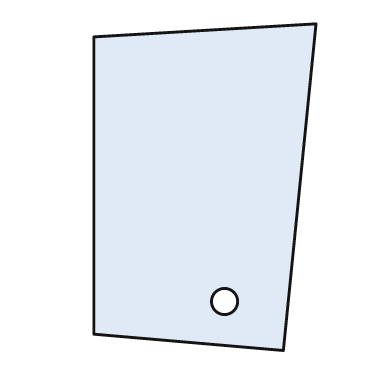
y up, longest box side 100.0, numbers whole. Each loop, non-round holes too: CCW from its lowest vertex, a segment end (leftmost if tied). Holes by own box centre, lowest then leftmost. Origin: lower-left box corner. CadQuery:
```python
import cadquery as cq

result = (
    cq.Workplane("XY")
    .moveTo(58.0, 0.0)
    .lineTo(68.0, 100.0)
    .lineTo(0.0, 96.0)
    .lineTo(0.0, 5.0)
    .close()
    .moveTo(40.0, 15.0)
    .circle(4.0)
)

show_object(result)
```